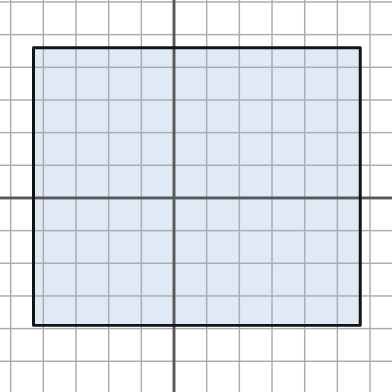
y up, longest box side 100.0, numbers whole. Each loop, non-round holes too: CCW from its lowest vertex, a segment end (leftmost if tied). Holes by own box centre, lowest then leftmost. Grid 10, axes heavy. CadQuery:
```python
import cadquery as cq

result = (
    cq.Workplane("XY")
    .moveTo(-43.0, -39.0)
    .lineTo(57.0, -39.0)
    .lineTo(57.0, 46.0)
    .lineTo(-43.0, 46.0)
    .close()
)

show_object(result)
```